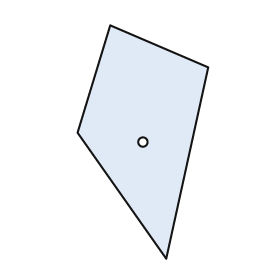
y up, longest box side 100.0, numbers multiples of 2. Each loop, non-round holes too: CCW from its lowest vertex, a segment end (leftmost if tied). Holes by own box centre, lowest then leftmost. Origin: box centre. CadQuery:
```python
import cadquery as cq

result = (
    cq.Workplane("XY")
    .moveTo(10.0, -50.0)
    .lineTo(28.0, 32.0)
    .lineTo(-14.0, 50.0)
    .lineTo(-28.0, 4.0)
    .close()
    .moveTo(0.0, 0.0)
    .circle(2.0)
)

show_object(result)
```